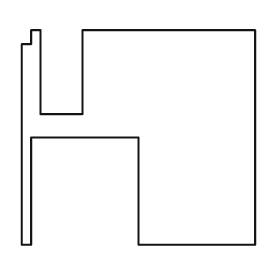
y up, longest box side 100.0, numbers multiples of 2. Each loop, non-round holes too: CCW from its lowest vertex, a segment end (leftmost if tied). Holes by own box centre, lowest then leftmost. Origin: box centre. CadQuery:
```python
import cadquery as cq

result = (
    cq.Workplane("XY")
    .moveTo(-50.0, -46.0)
    .lineTo(-46.0, -46.0)
    .lineTo(-46.0, 0.0)
    .lineTo(0.0, 0.0)
    .lineTo(0.0, -46.0)
    .lineTo(50.0, -46.0)
    .lineTo(50.0, 46.0)
    .lineTo(-24.0, 46.0)
    .lineTo(-24.0, 10.0)
    .lineTo(-42.0, 10.0)
    .lineTo(-42.0, 46.0)
    .lineTo(-46.0, 46.0)
    .lineTo(-46.0, 40.0)
    .lineTo(-50.0, 40.0)
    .close()
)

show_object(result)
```